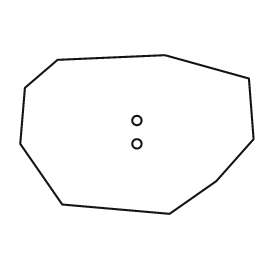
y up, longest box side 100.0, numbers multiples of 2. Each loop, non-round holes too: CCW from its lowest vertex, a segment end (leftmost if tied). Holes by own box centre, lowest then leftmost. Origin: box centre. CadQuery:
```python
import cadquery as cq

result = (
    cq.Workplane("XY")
    .moveTo(14.0, -34.0)
    .lineTo(34.0, -20.0)
    .lineTo(50.0, -2.0)
    .lineTo(48.0, 24.0)
    .lineTo(12.0, 34.0)
    .lineTo(-34.0, 32.0)
    .lineTo(-48.0, 20.0)
    .lineTo(-50.0, -4.0)
    .lineTo(-32.0, -30.0)
    .close()
    .moveTo(0.0, -4.0)
    .circle(2.0)
    .moveTo(0.0, 6.0)
    .circle(2.0)
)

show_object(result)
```